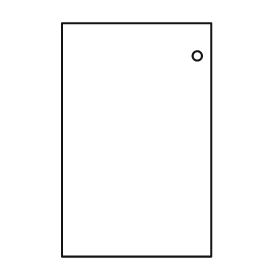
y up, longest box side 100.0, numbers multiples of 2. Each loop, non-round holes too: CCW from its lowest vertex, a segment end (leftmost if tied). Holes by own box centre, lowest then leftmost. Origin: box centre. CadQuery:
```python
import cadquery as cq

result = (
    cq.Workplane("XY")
    .moveTo(-32.0, -50.0)
    .lineTo(32.0, -50.0)
    .lineTo(32.0, 50.0)
    .lineTo(-32.0, 50.0)
    .close()
    .moveTo(26.0, 36.0)
    .circle(2.0)
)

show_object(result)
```